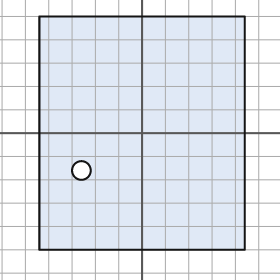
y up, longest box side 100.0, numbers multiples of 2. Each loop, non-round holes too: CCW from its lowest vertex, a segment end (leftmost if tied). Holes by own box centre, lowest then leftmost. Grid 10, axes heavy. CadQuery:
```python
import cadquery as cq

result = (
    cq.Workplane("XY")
    .moveTo(-44.0, -50.0)
    .lineTo(44.0, -50.0)
    .lineTo(44.0, 50.0)
    .lineTo(-44.0, 50.0)
    .close()
    .moveTo(-26.0, -16.0)
    .circle(4.0)
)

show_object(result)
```